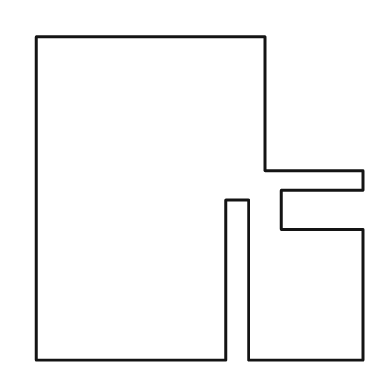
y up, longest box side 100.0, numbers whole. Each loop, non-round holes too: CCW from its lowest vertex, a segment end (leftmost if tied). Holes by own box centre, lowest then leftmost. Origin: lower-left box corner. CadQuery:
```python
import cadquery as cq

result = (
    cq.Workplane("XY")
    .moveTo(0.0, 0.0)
    .lineTo(58.0, 0.0)
    .lineTo(58.0, 49.0)
    .lineTo(65.0, 49.0)
    .lineTo(65.0, 0.0)
    .lineTo(100.0, 0.0)
    .lineTo(100.0, 40.0)
    .lineTo(75.0, 40.0)
    .lineTo(75.0, 52.0)
    .lineTo(100.0, 52.0)
    .lineTo(100.0, 58.0)
    .lineTo(70.0, 58.0)
    .lineTo(70.0, 99.0)
    .lineTo(0.0, 99.0)
    .close()
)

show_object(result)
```